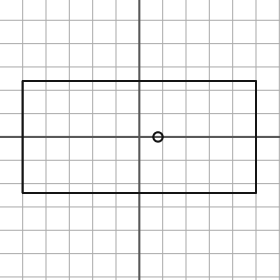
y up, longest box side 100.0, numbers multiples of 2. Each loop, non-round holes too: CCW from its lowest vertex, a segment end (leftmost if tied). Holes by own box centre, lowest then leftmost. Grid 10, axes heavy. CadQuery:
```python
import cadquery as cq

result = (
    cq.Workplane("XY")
    .moveTo(-50.0, -24.0)
    .lineTo(50.0, -24.0)
    .lineTo(50.0, 24.0)
    .lineTo(-50.0, 24.0)
    .close()
    .moveTo(8.0, 0.0)
    .circle(2.0)
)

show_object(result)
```